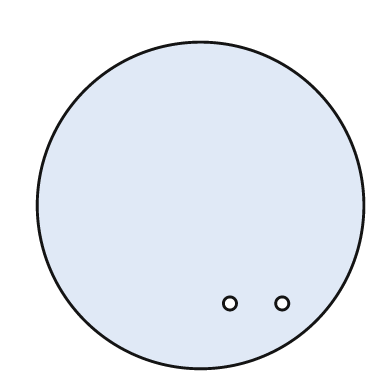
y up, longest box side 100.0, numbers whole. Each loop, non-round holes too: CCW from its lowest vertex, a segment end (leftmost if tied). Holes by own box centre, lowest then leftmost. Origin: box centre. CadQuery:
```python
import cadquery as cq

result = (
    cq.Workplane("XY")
    .moveTo(0.0, 0.0)
    .circle(50.0)
    .moveTo(9.0, -30.0)
    .circle(2.0)
    .moveTo(25.0, -30.0)
    .circle(2.0)
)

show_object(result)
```